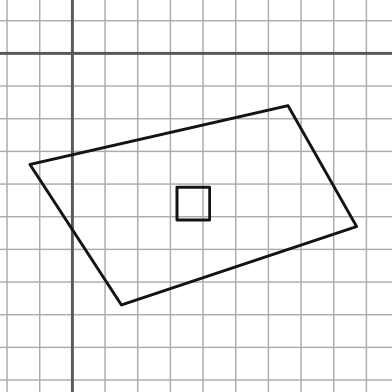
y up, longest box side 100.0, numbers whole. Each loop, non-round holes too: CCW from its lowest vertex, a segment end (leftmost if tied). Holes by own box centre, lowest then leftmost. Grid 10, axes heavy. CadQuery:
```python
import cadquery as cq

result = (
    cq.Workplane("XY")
    .moveTo(15.0, -77.0)
    .lineTo(87.0, -53.0)
    .lineTo(66.0, -16.0)
    .lineTo(-13.0, -34.0)
    .close()
    .moveTo(32.0, -51.0)
    .lineTo(42.0, -51.0)
    .lineTo(42.0, -41.0)
    .lineTo(32.0, -41.0)
    .close()
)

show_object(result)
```